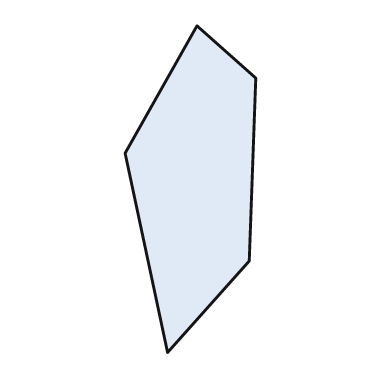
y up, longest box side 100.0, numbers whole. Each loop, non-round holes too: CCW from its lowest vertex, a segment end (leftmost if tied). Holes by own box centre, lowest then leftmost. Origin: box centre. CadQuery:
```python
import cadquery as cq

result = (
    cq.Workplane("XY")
    .moveTo(-7.0, -50.0)
    .lineTo(18.0, -22.0)
    .lineTo(20.0, 34.0)
    .lineTo(2.0, 50.0)
    .lineTo(-20.0, 11.0)
    .close()
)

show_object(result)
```